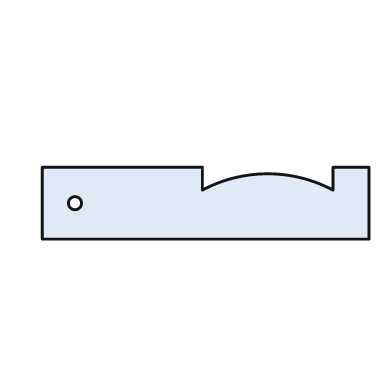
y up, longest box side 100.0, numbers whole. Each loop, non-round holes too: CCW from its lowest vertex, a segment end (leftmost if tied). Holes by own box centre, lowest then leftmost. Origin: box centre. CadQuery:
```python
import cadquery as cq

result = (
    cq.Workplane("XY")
    .moveTo(-50.0, -11.0)
    .lineTo(50.0, -11.0)
    .lineTo(50.0, 11.0)
    .lineTo(39.0, 11.0)
    .lineTo(39.0, 4.0)
    .threePointArc((19.0, 9.0), (-1.0, 4.0))
    .lineTo(-1.0, 11.0)
    .lineTo(-50.0, 11.0)
    .close()
    .moveTo(-40.0, 0.0)
    .circle(2.0)
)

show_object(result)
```